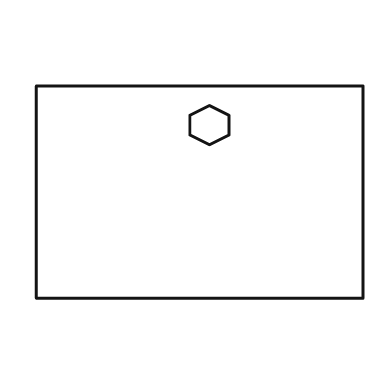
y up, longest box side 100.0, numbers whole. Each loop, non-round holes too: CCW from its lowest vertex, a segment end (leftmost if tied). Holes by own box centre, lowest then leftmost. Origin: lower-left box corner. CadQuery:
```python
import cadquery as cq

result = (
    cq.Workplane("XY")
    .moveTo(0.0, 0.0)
    .lineTo(100.0, 0.0)
    .lineTo(100.0, 65.0)
    .lineTo(0.0, 65.0)
    .close()
    .moveTo(53.0, 47.0)
    .lineTo(59.0, 50.0)
    .lineTo(59.0, 56.0)
    .lineTo(53.0, 59.0)
    .lineTo(47.0, 56.0)
    .lineTo(47.0, 50.0)
    .close()
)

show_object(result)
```